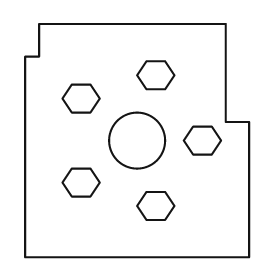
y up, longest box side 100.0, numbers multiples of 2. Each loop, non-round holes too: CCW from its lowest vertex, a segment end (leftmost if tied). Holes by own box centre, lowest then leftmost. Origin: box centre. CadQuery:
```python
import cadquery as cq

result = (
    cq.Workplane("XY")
    .moveTo(-48.0, -50.0)
    .lineTo(48.0, -50.0)
    .lineTo(48.0, 8.0)
    .lineTo(38.0, 8.0)
    .lineTo(38.0, 50.0)
    .lineTo(-42.0, 50.0)
    .lineTo(-42.0, 36.0)
    .lineTo(-48.0, 36.0)
    .close()
    .moveTo(4.0, -34.0)
    .lineTo(12.0, -34.0)
    .lineTo(16.0, -28.0)
    .lineTo(12.0, -22.0)
    .lineTo(4.0, -22.0)
    .lineTo(0.0, -28.0)
    .close()
    .moveTo(-28.0, -24.0)
    .lineTo(-20.0, -24.0)
    .lineTo(-16.0, -18.0)
    .lineTo(-20.0, -12.0)
    .lineTo(-28.0, -12.0)
    .lineTo(-32.0, -18.0)
    .close()
    .moveTo(0.0, 0.0)
    .circle(12.0)
    .moveTo(24.0, -6.0)
    .lineTo(32.0, -6.0)
    .lineTo(36.0, 0.0)
    .lineTo(32.0, 6.0)
    .lineTo(24.0, 6.0)
    .lineTo(20.0, 0.0)
    .close()
    .moveTo(-28.0, 12.0)
    .lineTo(-20.0, 12.0)
    .lineTo(-16.0, 18.0)
    .lineTo(-20.0, 24.0)
    .lineTo(-28.0, 24.0)
    .lineTo(-32.0, 18.0)
    .close()
    .moveTo(4.0, 22.0)
    .lineTo(12.0, 22.0)
    .lineTo(16.0, 28.0)
    .lineTo(12.0, 34.0)
    .lineTo(4.0, 34.0)
    .lineTo(0.0, 28.0)
    .close()
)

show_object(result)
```